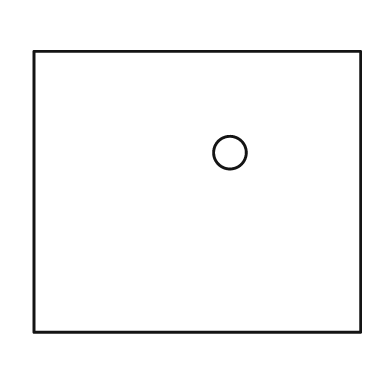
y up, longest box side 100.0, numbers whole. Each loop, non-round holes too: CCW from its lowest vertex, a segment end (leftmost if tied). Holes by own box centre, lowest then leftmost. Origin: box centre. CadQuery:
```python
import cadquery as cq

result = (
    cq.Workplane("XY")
    .moveTo(-50.0, -43.0)
    .lineTo(50.0, -43.0)
    .lineTo(50.0, 43.0)
    .lineTo(-50.0, 43.0)
    .close()
    .moveTo(10.0, 12.0)
    .circle(5.0)
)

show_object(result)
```